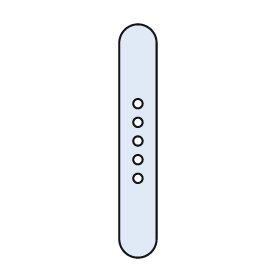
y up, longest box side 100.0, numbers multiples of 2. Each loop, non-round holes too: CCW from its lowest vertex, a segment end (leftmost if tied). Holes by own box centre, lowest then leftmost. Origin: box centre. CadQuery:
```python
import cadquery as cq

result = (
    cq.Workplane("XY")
    .moveTo(-8.0, -42.0)
    .threePointArc((0.0, -50.0), (8.0, -42.0))
    .lineTo(8.0, 42.0)
    .threePointArc((0.0, 50.0), (-8.0, 42.0))
    .close()
    .moveTo(0.0, -16.0)
    .circle(2.0)
    .moveTo(0.0, -8.0)
    .circle(2.0)
    .moveTo(0.0, 0.0)
    .circle(2.0)
    .moveTo(0.0, 8.0)
    .circle(2.0)
    .moveTo(0.0, 16.0)
    .circle(2.0)
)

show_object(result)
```